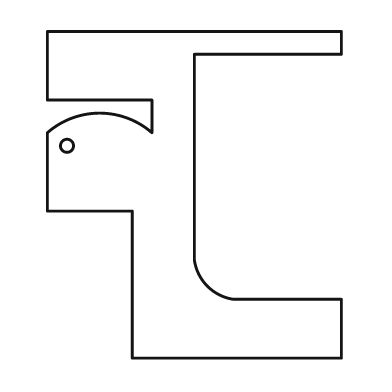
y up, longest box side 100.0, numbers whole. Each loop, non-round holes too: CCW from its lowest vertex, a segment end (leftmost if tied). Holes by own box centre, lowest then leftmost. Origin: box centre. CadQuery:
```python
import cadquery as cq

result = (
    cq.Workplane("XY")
    .moveTo(-19.0, -50.0)
    .lineTo(45.0, -50.0)
    .lineTo(45.0, -32.0)
    .lineTo(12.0, -32.0)
    .threePointArc((4.0, -28.0), (0.0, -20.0))
    .lineTo(0.0, 43.0)
    .lineTo(45.0, 43.0)
    .lineTo(45.0, 50.0)
    .lineTo(-45.0, 50.0)
    .lineTo(-45.0, 29.0)
    .lineTo(-13.0, 29.0)
    .lineTo(-13.0, 19.0)
    .threePointArc((-29.0, 25.0), (-45.0, 19.0))
    .lineTo(-45.0, -5.0)
    .lineTo(-19.0, -5.0)
    .close()
    .moveTo(-39.0, 15.0)
    .circle(2.0)
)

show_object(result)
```